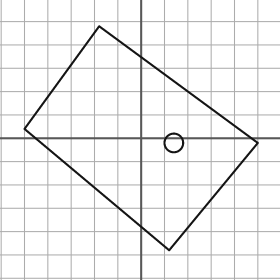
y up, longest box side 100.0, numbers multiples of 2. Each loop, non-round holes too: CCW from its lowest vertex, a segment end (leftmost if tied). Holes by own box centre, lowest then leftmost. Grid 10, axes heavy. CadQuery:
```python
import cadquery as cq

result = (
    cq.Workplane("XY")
    .moveTo(12.0, -48.0)
    .lineTo(50.0, -2.0)
    .lineTo(-18.0, 48.0)
    .lineTo(-50.0, 4.0)
    .close()
    .moveTo(14.0, -2.0)
    .circle(4.0)
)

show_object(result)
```